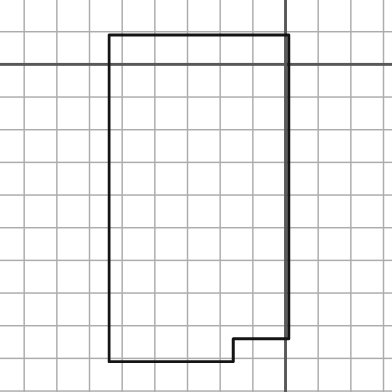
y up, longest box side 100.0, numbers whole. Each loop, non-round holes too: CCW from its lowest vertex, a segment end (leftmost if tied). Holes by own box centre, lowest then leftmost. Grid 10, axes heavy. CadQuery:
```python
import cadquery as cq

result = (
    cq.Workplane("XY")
    .moveTo(-54.0, -91.0)
    .lineTo(-16.0, -91.0)
    .lineTo(-16.0, -84.0)
    .lineTo(1.0, -84.0)
    .lineTo(1.0, 9.0)
    .lineTo(-54.0, 9.0)
    .close()
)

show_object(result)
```